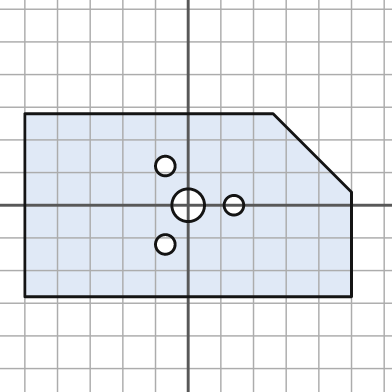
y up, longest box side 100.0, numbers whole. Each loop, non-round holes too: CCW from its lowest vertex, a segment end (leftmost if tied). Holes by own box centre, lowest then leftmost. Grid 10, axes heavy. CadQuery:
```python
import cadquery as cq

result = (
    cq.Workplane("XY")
    .moveTo(-50.0, -28.0)
    .lineTo(50.0, -28.0)
    .lineTo(50.0, 4.0)
    .lineTo(26.0, 28.0)
    .lineTo(-50.0, 28.0)
    .close()
    .moveTo(-7.0, -12.0)
    .circle(3.0)
    .moveTo(0.0, 0.0)
    .circle(5.0)
    .moveTo(14.0, 0.0)
    .circle(3.0)
    .moveTo(-7.0, 12.0)
    .circle(3.0)
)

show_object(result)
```